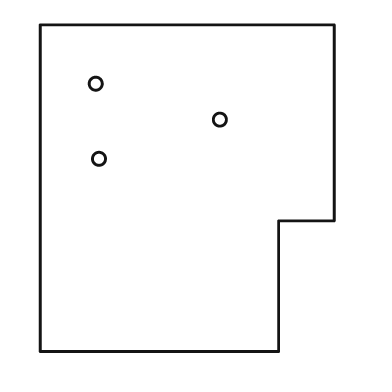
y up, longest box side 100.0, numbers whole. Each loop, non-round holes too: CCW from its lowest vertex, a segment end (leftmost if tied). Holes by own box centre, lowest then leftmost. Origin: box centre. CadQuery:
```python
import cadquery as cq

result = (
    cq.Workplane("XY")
    .moveTo(-45.0, -50.0)
    .lineTo(28.0, -50.0)
    .lineTo(28.0, -10.0)
    .lineTo(45.0, -10.0)
    .lineTo(45.0, 50.0)
    .lineTo(-45.0, 50.0)
    .close()
    .moveTo(-27.0, 9.0)
    .circle(2.0)
    .moveTo(10.0, 21.0)
    .circle(2.0)
    .moveTo(-28.0, 32.0)
    .circle(2.0)
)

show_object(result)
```